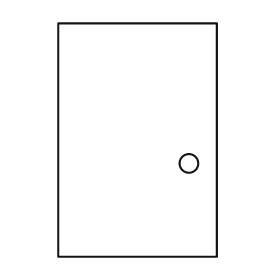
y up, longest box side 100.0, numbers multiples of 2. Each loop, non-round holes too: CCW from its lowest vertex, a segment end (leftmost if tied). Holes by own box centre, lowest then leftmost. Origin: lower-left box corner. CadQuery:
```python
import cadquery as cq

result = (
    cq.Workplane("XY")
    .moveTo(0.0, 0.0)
    .lineTo(68.0, 0.0)
    .lineTo(68.0, 100.0)
    .lineTo(0.0, 100.0)
    .close()
    .moveTo(56.0, 40.0)
    .circle(4.0)
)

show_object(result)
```